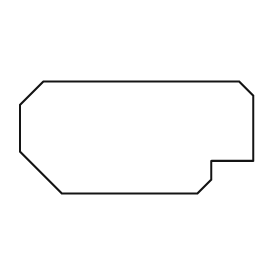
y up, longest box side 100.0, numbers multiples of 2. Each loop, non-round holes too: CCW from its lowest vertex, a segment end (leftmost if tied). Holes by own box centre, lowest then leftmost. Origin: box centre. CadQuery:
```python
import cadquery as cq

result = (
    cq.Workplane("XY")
    .moveTo(-32.0, -24.0)
    .lineTo(26.0, -24.0)
    .lineTo(32.0, -18.0)
    .lineTo(32.0, -10.0)
    .lineTo(50.0, -10.0)
    .lineTo(50.0, 18.0)
    .lineTo(44.0, 24.0)
    .lineTo(-40.0, 24.0)
    .lineTo(-50.0, 14.0)
    .lineTo(-50.0, -6.0)
    .close()
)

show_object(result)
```